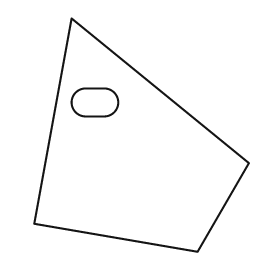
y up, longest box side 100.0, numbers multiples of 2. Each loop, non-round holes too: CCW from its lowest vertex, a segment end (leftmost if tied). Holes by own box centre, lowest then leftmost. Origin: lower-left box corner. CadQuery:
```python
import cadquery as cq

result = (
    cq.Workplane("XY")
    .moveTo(70.0, 0.0)
    .lineTo(92.0, 38.0)
    .lineTo(16.0, 100.0)
    .lineTo(0.0, 12.0)
    .close()
    .moveTo(22.0, 58.0)
    .lineTo(30.0, 58.0)
    .threePointArc((36.0, 64.0), (30.0, 70.0))
    .lineTo(22.0, 70.0)
    .threePointArc((16.0, 64.0), (22.0, 58.0))
    .close()
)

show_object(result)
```